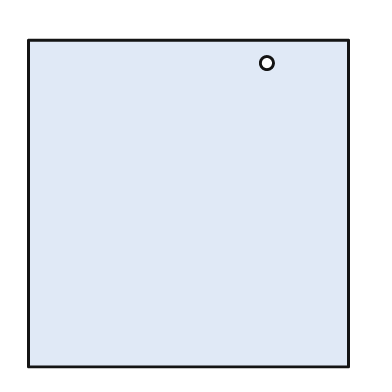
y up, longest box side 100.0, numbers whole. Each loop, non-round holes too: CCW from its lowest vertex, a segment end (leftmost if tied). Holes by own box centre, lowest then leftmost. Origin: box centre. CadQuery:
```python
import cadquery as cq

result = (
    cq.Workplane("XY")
    .moveTo(-49.0, -50.0)
    .lineTo(49.0, -50.0)
    .lineTo(49.0, 50.0)
    .lineTo(-49.0, 50.0)
    .close()
    .moveTo(24.0, 43.0)
    .circle(2.0)
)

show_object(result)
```